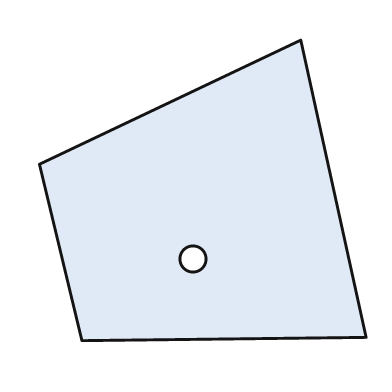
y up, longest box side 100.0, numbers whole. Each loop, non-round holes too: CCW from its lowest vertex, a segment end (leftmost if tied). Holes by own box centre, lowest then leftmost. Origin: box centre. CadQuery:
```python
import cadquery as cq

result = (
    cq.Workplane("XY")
    .moveTo(-37.0, -46.0)
    .lineTo(50.0, -45.0)
    .lineTo(30.0, 46.0)
    .lineTo(-50.0, 8.0)
    .close()
    .moveTo(-3.0, -21.0)
    .circle(4.0)
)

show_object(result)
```